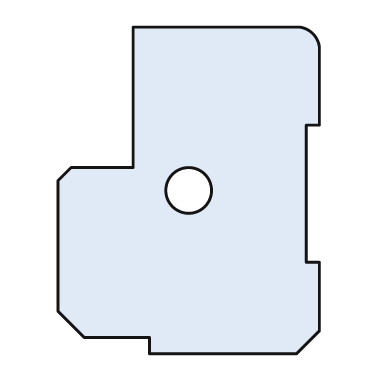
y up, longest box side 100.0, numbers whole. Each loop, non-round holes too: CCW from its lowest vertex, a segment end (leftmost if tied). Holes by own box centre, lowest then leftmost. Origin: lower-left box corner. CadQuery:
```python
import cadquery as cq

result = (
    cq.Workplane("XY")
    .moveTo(28.0, 0.0)
    .lineTo(73.0, 0.0)
    .lineTo(80.0, 7.0)
    .lineTo(80.0, 28.0)
    .lineTo(76.0, 28.0)
    .lineTo(76.0, 70.0)
    .lineTo(80.0, 70.0)
    .lineTo(80.0, 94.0)
    .threePointArc((78.0, 98.0), (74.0, 100.0))
    .lineTo(23.0, 100.0)
    .lineTo(23.0, 57.0)
    .lineTo(4.0, 57.0)
    .lineTo(0.0, 53.0)
    .lineTo(0.0, 13.0)
    .lineTo(8.0, 5.0)
    .lineTo(28.0, 5.0)
    .close()
    .moveTo(40.0, 50.0)
    .circle(7.0)
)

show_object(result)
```